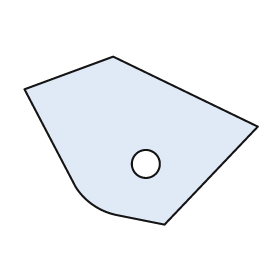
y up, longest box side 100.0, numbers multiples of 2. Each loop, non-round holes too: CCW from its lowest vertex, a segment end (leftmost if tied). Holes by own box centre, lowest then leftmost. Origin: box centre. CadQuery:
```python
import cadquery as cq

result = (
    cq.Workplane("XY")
    .moveTo(10.0, -36.0)
    .lineTo(50.0, 6.0)
    .lineTo(-12.0, 36.0)
    .lineTo(-50.0, 22.0)
    .lineTo(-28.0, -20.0)
    .threePointArc((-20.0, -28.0), (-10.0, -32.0))
    .close()
    .moveTo(2.0, -10.0)
    .circle(6.0)
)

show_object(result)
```